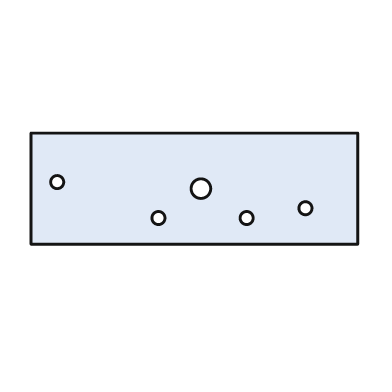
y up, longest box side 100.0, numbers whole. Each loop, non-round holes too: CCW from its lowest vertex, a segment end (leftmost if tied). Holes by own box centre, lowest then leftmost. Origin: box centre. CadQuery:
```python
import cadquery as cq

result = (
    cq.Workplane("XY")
    .moveTo(-50.0, -17.0)
    .lineTo(50.0, -17.0)
    .lineTo(50.0, 17.0)
    .lineTo(-50.0, 17.0)
    .close()
    .moveTo(-11.0, -9.0)
    .circle(2.0)
    .moveTo(16.0, -9.0)
    .circle(2.0)
    .moveTo(34.0, -6.0)
    .circle(2.0)
    .moveTo(2.0, 0.0)
    .circle(3.0)
    .moveTo(-42.0, 2.0)
    .circle(2.0)
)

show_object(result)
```